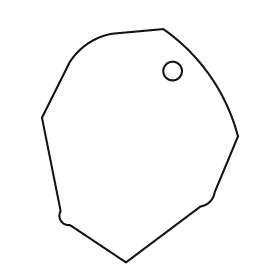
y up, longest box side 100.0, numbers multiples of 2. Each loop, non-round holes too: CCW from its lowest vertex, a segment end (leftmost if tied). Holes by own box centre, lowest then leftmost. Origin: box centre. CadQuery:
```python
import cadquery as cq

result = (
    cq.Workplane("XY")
    .moveTo(-6.0, -50.0)
    .lineTo(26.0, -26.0)
    .threePointArc((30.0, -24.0), (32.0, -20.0))
    .lineTo(42.0, 4.0)
    .threePointArc((30.0, 30.0), (10.0, 50.0))
    .lineTo(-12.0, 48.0)
    .threePointArc((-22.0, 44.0), (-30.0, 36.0))
    .lineTo(-42.0, 12.0)
    .lineTo(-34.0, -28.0)
    .threePointArc((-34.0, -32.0), (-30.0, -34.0))
    .close()
    .moveTo(14.0, 32.0)
    .circle(4.0)
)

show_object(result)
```